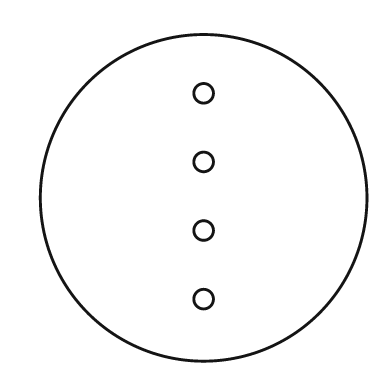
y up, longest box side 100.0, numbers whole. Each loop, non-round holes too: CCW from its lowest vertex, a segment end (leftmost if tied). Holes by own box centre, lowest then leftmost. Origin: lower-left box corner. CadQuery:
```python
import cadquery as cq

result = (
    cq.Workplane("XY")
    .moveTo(50.0, 50.0)
    .circle(50.0)
    .moveTo(50.0, 19.0)
    .circle(3.0)
    .moveTo(50.0, 40.0)
    .circle(3.0)
    .moveTo(50.0, 61.0)
    .circle(3.0)
    .moveTo(50.0, 82.0)
    .circle(3.0)
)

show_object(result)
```